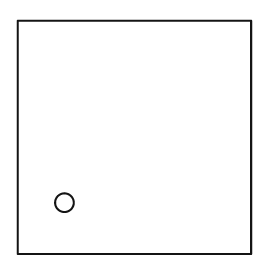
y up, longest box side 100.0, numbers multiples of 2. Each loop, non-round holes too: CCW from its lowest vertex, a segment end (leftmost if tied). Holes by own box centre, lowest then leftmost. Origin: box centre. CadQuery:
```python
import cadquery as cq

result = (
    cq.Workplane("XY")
    .moveTo(-50.0, -50.0)
    .lineTo(50.0, -50.0)
    .lineTo(50.0, 50.0)
    .lineTo(-50.0, 50.0)
    .close()
    .moveTo(-30.0, -28.0)
    .circle(4.0)
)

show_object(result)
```